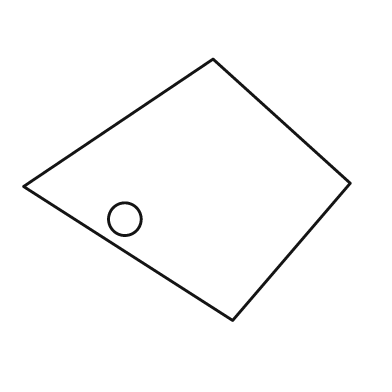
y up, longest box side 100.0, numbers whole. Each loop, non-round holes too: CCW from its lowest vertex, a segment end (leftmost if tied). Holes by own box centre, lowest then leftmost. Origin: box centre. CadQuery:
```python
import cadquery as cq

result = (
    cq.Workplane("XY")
    .moveTo(14.0, -40.0)
    .lineTo(50.0, 2.0)
    .lineTo(8.0, 40.0)
    .lineTo(-50.0, 1.0)
    .close()
    .moveTo(-19.0, -9.0)
    .circle(5.0)
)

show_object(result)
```